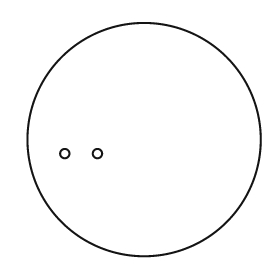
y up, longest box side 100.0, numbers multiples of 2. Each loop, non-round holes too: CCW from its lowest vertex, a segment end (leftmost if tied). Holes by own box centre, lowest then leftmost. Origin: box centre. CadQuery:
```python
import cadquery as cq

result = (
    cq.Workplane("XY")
    .moveTo(0.0, 0.0)
    .circle(50.0)
    .moveTo(-34.0, -6.0)
    .circle(2.0)
    .moveTo(-20.0, -6.0)
    .circle(2.0)
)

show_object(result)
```